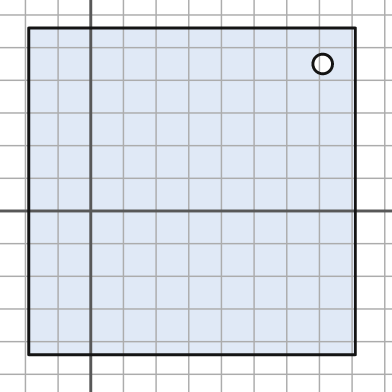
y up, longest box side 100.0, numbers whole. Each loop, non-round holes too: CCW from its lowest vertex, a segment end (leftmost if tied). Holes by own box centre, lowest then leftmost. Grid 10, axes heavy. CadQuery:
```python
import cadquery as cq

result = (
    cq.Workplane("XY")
    .moveTo(-19.0, -44.0)
    .lineTo(81.0, -44.0)
    .lineTo(81.0, 56.0)
    .lineTo(-19.0, 56.0)
    .close()
    .moveTo(71.0, 45.0)
    .circle(3.0)
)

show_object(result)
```